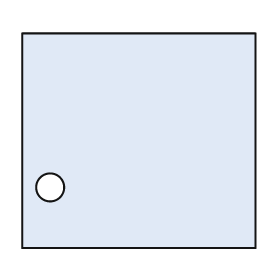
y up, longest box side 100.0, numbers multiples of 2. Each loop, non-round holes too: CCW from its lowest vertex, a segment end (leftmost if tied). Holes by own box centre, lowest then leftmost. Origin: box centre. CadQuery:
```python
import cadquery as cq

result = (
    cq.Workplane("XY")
    .moveTo(-50.0, -46.0)
    .lineTo(50.0, -46.0)
    .lineTo(50.0, 46.0)
    .lineTo(-50.0, 46.0)
    .close()
    .moveTo(-38.0, -20.0)
    .circle(6.0)
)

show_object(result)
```